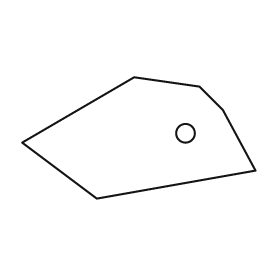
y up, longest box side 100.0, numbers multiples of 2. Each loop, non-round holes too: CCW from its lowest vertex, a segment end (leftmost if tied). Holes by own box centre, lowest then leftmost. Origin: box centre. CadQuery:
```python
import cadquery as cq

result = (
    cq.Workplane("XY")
    .moveTo(-18.0, -26.0)
    .lineTo(50.0, -14.0)
    .lineTo(36.0, 12.0)
    .lineTo(26.0, 22.0)
    .lineTo(-2.0, 26.0)
    .lineTo(-50.0, -2.0)
    .close()
    .moveTo(20.0, 2.0)
    .circle(4.0)
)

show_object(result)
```